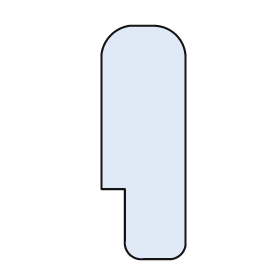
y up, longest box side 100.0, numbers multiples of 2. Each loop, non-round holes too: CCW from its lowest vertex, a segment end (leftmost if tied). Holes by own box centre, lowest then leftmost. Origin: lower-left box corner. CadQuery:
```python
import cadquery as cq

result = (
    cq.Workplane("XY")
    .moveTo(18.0, 0.0)
    .lineTo(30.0, 0.0)
    .threePointArc((34.0, 2.0), (36.0, 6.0))
    .lineTo(36.0, 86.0)
    .threePointArc((32.0, 96.0), (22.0, 100.0))
    .lineTo(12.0, 100.0)
    .threePointArc((4.0, 96.0), (0.0, 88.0))
    .lineTo(0.0, 30.0)
    .lineTo(10.0, 30.0)
    .lineTo(10.0, 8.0)
    .threePointArc((12.0, 2.0), (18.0, 0.0))
    .close()
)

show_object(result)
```